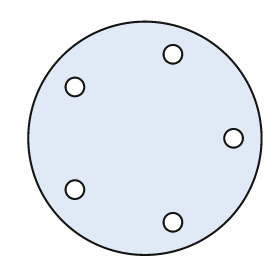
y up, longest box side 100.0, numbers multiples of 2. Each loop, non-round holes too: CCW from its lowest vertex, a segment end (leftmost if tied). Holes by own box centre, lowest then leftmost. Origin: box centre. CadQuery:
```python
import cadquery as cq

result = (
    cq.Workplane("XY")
    .moveTo(0.0, 0.0)
    .circle(50.0)
    .moveTo(12.0, -36.0)
    .circle(4.0)
    .moveTo(-30.0, -22.0)
    .circle(4.0)
    .moveTo(38.0, 0.0)
    .circle(4.0)
    .moveTo(-30.0, 22.0)
    .circle(4.0)
    .moveTo(12.0, 36.0)
    .circle(4.0)
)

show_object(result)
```